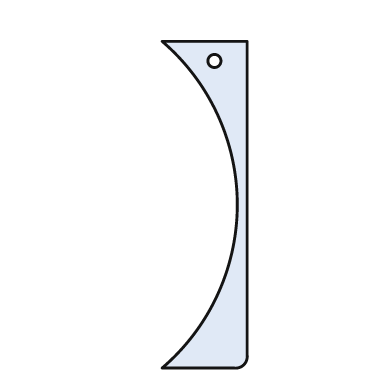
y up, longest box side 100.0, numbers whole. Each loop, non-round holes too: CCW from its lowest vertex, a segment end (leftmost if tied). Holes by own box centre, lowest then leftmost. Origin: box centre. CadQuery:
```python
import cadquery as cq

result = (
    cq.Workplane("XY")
    .moveTo(-13.0, -50.0)
    .lineTo(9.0, -50.0)
    .threePointArc((12.0, -49.0), (13.0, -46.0))
    .lineTo(13.0, 50.0)
    .lineTo(-13.0, 50.0)
    .threePointArc((10.0, 0.0), (-13.0, -50.0))
    .close()
    .moveTo(3.0, 44.0)
    .circle(2.0)
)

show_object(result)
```